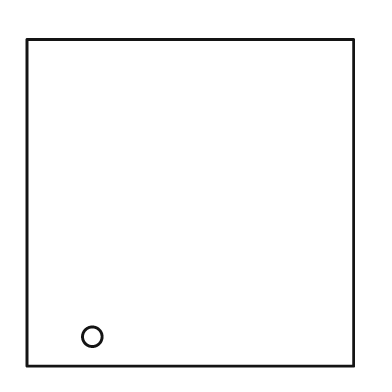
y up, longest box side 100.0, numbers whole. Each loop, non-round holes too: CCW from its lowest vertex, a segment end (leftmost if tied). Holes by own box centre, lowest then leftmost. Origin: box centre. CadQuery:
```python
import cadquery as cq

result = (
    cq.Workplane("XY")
    .moveTo(-50.0, -50.0)
    .lineTo(50.0, -50.0)
    .lineTo(50.0, 50.0)
    .lineTo(-50.0, 50.0)
    .close()
    .moveTo(-30.0, -41.0)
    .circle(3.0)
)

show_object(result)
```